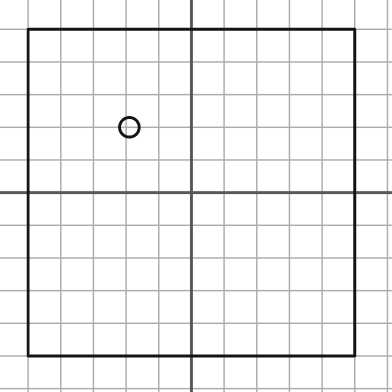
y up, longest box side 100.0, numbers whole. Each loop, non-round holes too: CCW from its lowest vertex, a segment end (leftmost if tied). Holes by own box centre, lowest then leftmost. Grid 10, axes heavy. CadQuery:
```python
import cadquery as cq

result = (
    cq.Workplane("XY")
    .moveTo(-50.0, -50.0)
    .lineTo(50.0, -50.0)
    .lineTo(50.0, 50.0)
    .lineTo(-50.0, 50.0)
    .close()
    .moveTo(-19.0, 20.0)
    .circle(3.0)
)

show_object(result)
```